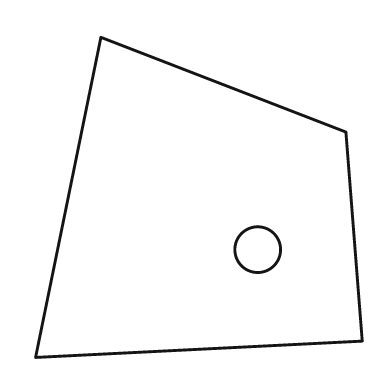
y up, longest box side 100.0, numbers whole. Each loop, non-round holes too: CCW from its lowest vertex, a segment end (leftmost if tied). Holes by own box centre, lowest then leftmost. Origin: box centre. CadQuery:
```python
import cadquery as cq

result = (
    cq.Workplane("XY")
    .moveTo(-50.0, -49.0)
    .lineTo(50.0, -44.0)
    .lineTo(45.0, 20.0)
    .lineTo(-30.0, 49.0)
    .close()
    .moveTo(18.0, -16.0)
    .circle(7.0)
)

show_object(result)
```